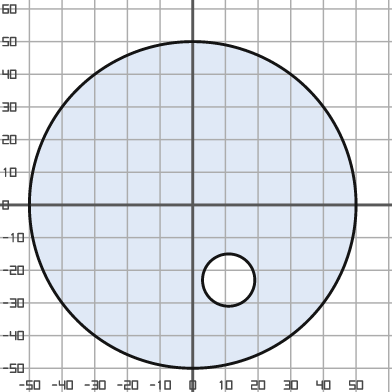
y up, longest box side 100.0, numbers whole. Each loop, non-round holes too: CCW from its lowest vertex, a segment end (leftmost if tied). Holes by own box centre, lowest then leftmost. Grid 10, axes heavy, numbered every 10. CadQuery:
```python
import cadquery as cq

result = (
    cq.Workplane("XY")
    .moveTo(0.0, 0.0)
    .circle(50.0)
    .moveTo(11.0, -23.0)
    .circle(8.0)
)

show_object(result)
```